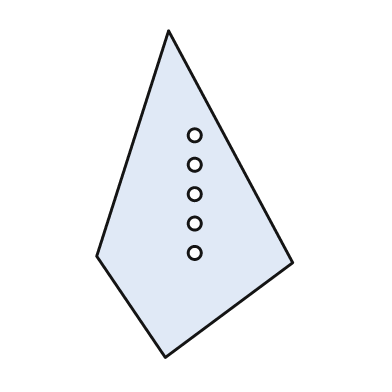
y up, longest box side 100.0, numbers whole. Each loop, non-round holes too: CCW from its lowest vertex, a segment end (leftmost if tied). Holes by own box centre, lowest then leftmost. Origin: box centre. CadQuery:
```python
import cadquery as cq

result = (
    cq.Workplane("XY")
    .moveTo(-9.0, -50.0)
    .lineTo(30.0, -21.0)
    .lineTo(-8.0, 50.0)
    .lineTo(-30.0, -19.0)
    .close()
    .moveTo(0.0, -18.0)
    .circle(2.0)
    .moveTo(0.0, -9.0)
    .circle(2.0)
    .moveTo(0.0, 0.0)
    .circle(2.0)
    .moveTo(0.0, 9.0)
    .circle(2.0)
    .moveTo(0.0, 18.0)
    .circle(2.0)
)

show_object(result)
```